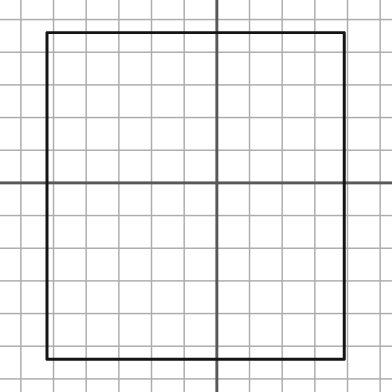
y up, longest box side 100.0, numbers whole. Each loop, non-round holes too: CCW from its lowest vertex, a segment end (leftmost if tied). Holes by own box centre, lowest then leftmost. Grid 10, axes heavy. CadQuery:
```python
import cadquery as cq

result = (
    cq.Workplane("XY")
    .moveTo(-52.0, -54.0)
    .lineTo(39.0, -54.0)
    .lineTo(39.0, 46.0)
    .lineTo(-52.0, 46.0)
    .close()
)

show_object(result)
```